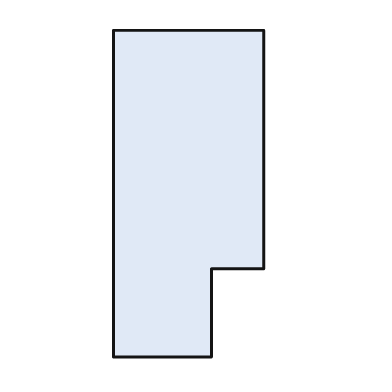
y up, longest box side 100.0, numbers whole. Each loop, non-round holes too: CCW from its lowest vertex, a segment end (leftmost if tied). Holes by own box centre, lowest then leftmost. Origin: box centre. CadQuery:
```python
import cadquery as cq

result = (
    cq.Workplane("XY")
    .moveTo(-23.0, -50.0)
    .lineTo(7.0, -50.0)
    .lineTo(7.0, -23.0)
    .lineTo(23.0, -23.0)
    .lineTo(23.0, 50.0)
    .lineTo(-23.0, 50.0)
    .close()
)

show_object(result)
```